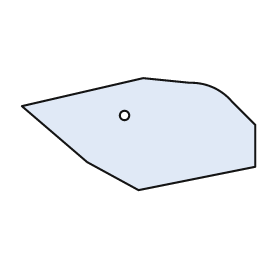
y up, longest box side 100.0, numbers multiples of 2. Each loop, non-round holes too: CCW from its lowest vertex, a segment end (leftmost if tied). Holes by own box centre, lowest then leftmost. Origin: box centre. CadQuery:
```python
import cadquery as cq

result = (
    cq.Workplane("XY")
    .moveTo(0.0, -24.0)
    .lineTo(50.0, -14.0)
    .lineTo(50.0, 4.0)
    .lineTo(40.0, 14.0)
    .threePointArc((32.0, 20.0), (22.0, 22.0))
    .lineTo(2.0, 24.0)
    .lineTo(-50.0, 12.0)
    .lineTo(-22.0, -12.0)
    .close()
    .moveTo(-6.0, 8.0)
    .circle(2.0)
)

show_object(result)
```